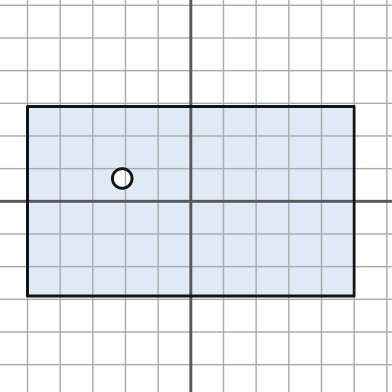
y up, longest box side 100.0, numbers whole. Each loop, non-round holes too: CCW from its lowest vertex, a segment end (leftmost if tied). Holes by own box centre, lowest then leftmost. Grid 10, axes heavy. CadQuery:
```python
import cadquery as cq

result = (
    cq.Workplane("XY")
    .moveTo(-50.0, -29.0)
    .lineTo(50.0, -29.0)
    .lineTo(50.0, 29.0)
    .lineTo(-50.0, 29.0)
    .close()
    .moveTo(-21.0, 7.0)
    .circle(3.0)
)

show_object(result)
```